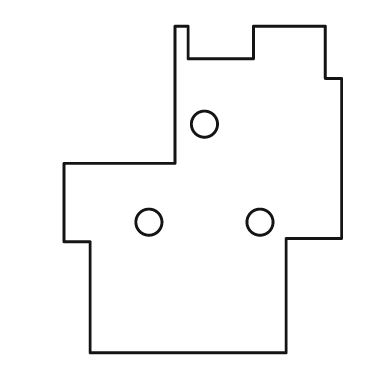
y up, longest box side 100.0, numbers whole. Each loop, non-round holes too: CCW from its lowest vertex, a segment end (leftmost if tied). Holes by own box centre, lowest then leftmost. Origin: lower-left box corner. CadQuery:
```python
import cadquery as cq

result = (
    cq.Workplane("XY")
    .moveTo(8.0, 0.0)
    .lineTo(68.0, 0.0)
    .lineTo(68.0, 35.0)
    .lineTo(85.0, 35.0)
    .lineTo(85.0, 84.0)
    .lineTo(80.0, 84.0)
    .lineTo(80.0, 100.0)
    .lineTo(58.0, 100.0)
    .lineTo(58.0, 90.0)
    .lineTo(38.0, 90.0)
    .lineTo(38.0, 100.0)
    .lineTo(34.0, 100.0)
    .lineTo(34.0, 58.0)
    .lineTo(0.0, 58.0)
    .lineTo(0.0, 34.0)
    .lineTo(8.0, 34.0)
    .close()
    .moveTo(26.0, 40.0)
    .circle(4.0)
    .moveTo(60.0, 40.0)
    .circle(4.0)
    .moveTo(43.0, 70.0)
    .circle(4.0)
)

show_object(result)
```